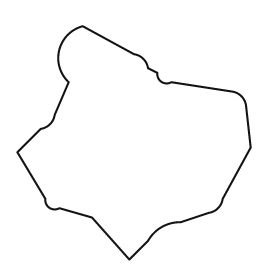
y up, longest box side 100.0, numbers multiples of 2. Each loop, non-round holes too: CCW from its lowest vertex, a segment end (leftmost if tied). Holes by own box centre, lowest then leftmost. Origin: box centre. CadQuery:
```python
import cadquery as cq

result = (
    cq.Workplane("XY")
    .moveTo(-2.0, -50.0)
    .lineTo(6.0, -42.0)
    .threePointArc((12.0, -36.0), (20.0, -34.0))
    .lineTo(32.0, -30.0)
    .threePointArc((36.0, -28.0), (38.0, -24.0))
    .lineTo(50.0, -2.0)
    .lineTo(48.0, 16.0)
    .threePointArc((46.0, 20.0), (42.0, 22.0))
    .lineTo(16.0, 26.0)
    .threePointArc((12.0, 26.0), (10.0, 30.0))
    .lineTo(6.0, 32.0)
    .threePointArc((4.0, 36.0), (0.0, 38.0))
    .lineTo(-22.0, 50.0)
    .threePointArc((-32.0, 40.0), (-28.0, 26.0))
    .lineTo(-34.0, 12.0)
    .threePointArc((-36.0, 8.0), (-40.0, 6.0))
    .lineTo(-50.0, -4.0)
    .lineTo(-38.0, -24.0)
    .threePointArc((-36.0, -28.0), (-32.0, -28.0))
    .lineTo(-18.0, -32.0)
    .close()
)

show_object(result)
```